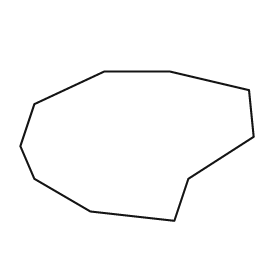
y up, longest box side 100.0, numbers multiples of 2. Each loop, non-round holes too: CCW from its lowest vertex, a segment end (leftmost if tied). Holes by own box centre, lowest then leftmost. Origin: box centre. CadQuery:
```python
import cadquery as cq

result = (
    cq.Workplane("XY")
    .moveTo(16.0, -32.0)
    .lineTo(22.0, -14.0)
    .lineTo(50.0, 4.0)
    .lineTo(48.0, 24.0)
    .lineTo(14.0, 32.0)
    .lineTo(-14.0, 32.0)
    .lineTo(-44.0, 18.0)
    .lineTo(-50.0, 0.0)
    .lineTo(-44.0, -14.0)
    .lineTo(-20.0, -28.0)
    .close()
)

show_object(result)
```